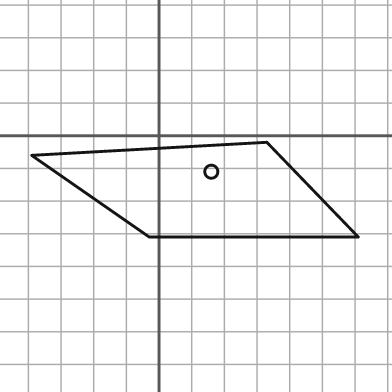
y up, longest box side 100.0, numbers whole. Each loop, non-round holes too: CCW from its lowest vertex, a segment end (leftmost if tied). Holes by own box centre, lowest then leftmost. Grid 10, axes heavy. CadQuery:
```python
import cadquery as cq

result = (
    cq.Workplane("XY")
    .moveTo(-3.0, -31.0)
    .lineTo(61.0, -31.0)
    .lineTo(33.0, -2.0)
    .lineTo(-39.0, -6.0)
    .close()
    .moveTo(16.0, -11.0)
    .circle(2.0)
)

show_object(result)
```